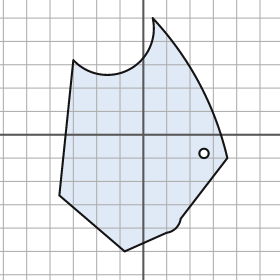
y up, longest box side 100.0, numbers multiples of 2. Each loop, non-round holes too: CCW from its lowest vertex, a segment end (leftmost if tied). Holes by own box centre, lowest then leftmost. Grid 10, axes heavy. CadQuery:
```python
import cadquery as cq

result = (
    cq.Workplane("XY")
    .moveTo(-8.0, -50.0)
    .lineTo(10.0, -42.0)
    .threePointArc((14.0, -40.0), (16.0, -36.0))
    .lineTo(36.0, -10.0)
    .threePointArc((24.0, 22.0), (4.0, 50.0))
    .threePointArc((-6.0, 28.0), (-30.0, 32.0))
    .lineTo(-36.0, -26.0)
    .close()
    .moveTo(26.0, -8.0)
    .circle(2.0)
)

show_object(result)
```